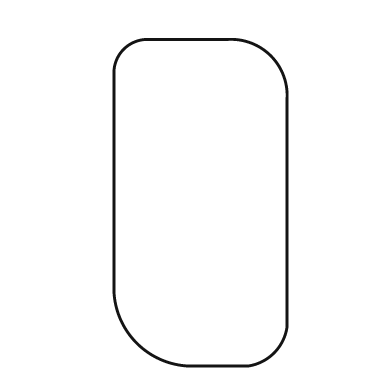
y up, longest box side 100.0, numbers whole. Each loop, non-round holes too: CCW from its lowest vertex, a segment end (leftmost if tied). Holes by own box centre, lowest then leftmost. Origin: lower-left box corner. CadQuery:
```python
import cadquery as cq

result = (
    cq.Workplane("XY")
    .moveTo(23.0, 0.0)
    .lineTo(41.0, 0.0)
    .threePointArc((49.0, 4.0), (53.0, 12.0))
    .lineTo(53.0, 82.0)
    .threePointArc((48.0, 95.0), (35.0, 100.0))
    .lineTo(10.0, 100.0)
    .threePointArc((3.0, 97.0), (0.0, 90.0))
    .lineTo(0.0, 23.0)
    .threePointArc((7.0, 7.0), (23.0, 0.0))
    .close()
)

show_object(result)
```